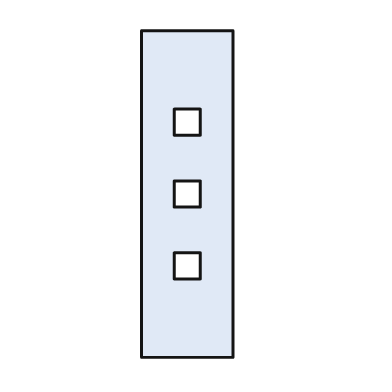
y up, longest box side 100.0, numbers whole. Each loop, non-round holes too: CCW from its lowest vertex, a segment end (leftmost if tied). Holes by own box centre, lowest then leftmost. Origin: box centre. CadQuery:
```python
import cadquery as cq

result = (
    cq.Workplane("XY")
    .moveTo(-14.0, -50.0)
    .lineTo(14.0, -50.0)
    .lineTo(14.0, 50.0)
    .lineTo(-14.0, 50.0)
    .close()
    .moveTo(-4.0, -26.0)
    .lineTo(4.0, -26.0)
    .lineTo(4.0, -18.0)
    .lineTo(-4.0, -18.0)
    .close()
    .moveTo(-4.0, -4.0)
    .lineTo(4.0, -4.0)
    .lineTo(4.0, 4.0)
    .lineTo(-4.0, 4.0)
    .close()
    .moveTo(-4.0, 18.0)
    .lineTo(4.0, 18.0)
    .lineTo(4.0, 26.0)
    .lineTo(-4.0, 26.0)
    .close()
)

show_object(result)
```